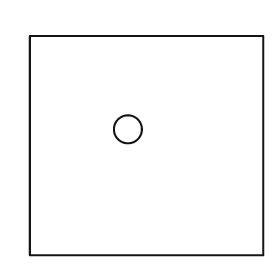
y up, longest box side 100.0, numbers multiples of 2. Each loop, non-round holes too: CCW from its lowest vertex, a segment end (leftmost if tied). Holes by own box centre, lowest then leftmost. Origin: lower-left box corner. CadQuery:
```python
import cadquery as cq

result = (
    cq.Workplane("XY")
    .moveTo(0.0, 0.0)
    .lineTo(100.0, 0.0)
    .lineTo(100.0, 94.0)
    .lineTo(0.0, 94.0)
    .close()
    .moveTo(42.0, 54.0)
    .circle(6.0)
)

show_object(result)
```